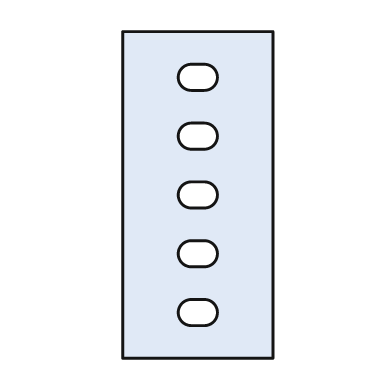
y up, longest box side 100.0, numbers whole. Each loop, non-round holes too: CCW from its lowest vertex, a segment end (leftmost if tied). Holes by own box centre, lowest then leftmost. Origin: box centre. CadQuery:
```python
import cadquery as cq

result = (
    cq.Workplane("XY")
    .moveTo(-23.0, -50.0)
    .lineTo(23.0, -50.0)
    .lineTo(23.0, 50.0)
    .lineTo(-23.0, 50.0)
    .close()
    .moveTo(-2.0, -40.0)
    .lineTo(2.0, -40.0)
    .threePointArc((6.0, -36.0), (2.0, -32.0))
    .lineTo(-2.0, -32.0)
    .threePointArc((-6.0, -36.0), (-2.0, -40.0))
    .close()
    .moveTo(-2.0, -22.0)
    .lineTo(2.0, -22.0)
    .threePointArc((6.0, -18.0), (2.0, -14.0))
    .lineTo(-2.0, -14.0)
    .threePointArc((-6.0, -18.0), (-2.0, -22.0))
    .close()
    .moveTo(-2.0, -4.0)
    .lineTo(2.0, -4.0)
    .threePointArc((6.0, 0.0), (2.0, 4.0))
    .lineTo(-2.0, 4.0)
    .threePointArc((-6.0, 0.0), (-2.0, -4.0))
    .close()
    .moveTo(-2.0, 14.0)
    .lineTo(2.0, 14.0)
    .threePointArc((6.0, 18.0), (2.0, 22.0))
    .lineTo(-2.0, 22.0)
    .threePointArc((-6.0, 18.0), (-2.0, 14.0))
    .close()
    .moveTo(-2.0, 32.0)
    .lineTo(2.0, 32.0)
    .threePointArc((6.0, 36.0), (2.0, 40.0))
    .lineTo(-2.0, 40.0)
    .threePointArc((-6.0, 36.0), (-2.0, 32.0))
    .close()
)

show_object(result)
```